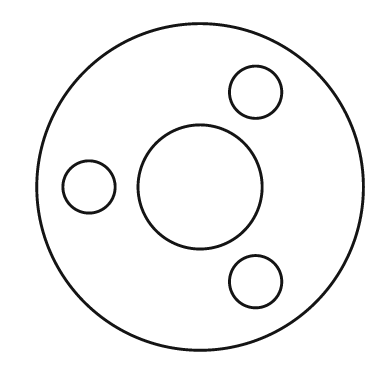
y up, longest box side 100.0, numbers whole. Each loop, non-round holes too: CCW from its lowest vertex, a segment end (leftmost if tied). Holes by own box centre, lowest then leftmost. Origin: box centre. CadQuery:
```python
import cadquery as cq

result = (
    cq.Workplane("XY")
    .moveTo(0.0, 0.0)
    .circle(50.0)
    .moveTo(17.0, -29.0)
    .circle(8.0)
    .moveTo(-34.0, 0.0)
    .circle(8.0)
    .moveTo(0.0, 0.0)
    .circle(19.0)
    .moveTo(17.0, 29.0)
    .circle(8.0)
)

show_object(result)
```